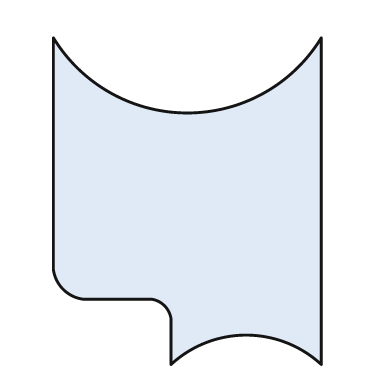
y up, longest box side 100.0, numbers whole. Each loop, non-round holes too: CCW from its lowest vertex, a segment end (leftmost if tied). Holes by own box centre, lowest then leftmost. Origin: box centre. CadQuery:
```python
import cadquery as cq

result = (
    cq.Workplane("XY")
    .moveTo(-5.0, -50.0)
    .threePointArc((18.0, -41.0), (41.0, -50.0))
    .lineTo(41.0, 50.0)
    .threePointArc((0.0, 27.0), (-41.0, 50.0))
    .lineTo(-41.0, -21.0)
    .threePointArc((-38.0, -27.0), (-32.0, -30.0))
    .lineTo(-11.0, -30.0)
    .threePointArc((-7.0, -32.0), (-5.0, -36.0))
    .close()
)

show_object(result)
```